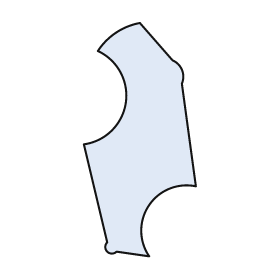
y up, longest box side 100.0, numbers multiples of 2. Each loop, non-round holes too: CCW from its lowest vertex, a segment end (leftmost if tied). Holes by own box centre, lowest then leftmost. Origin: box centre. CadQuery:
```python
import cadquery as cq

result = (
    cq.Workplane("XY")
    .moveTo(4.0, -50.0)
    .threePointArc((4.0, -28.0), (24.0, -20.0))
    .lineTo(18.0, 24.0)
    .threePointArc((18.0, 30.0), (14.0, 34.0))
    .lineTo(0.0, 50.0)
    .threePointArc((-10.0, 46.0), (-18.0, 38.0))
    .threePointArc((-6.0, 16.0), (-24.0, -2.0))
    .lineTo(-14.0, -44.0)
    .threePointArc((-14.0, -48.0), (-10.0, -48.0))
    .close()
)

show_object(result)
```